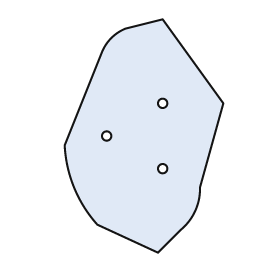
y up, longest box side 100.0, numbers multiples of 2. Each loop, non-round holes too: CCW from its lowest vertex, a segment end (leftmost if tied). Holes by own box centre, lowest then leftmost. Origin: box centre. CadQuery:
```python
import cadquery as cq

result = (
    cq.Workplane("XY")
    .moveTo(6.0, -50.0)
    .lineTo(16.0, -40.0)
    .threePointArc((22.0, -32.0), (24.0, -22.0))
    .lineTo(34.0, 14.0)
    .lineTo(8.0, 50.0)
    .lineTo(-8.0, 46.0)
    .threePointArc((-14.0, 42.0), (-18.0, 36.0))
    .lineTo(-34.0, -4.0)
    .threePointArc((-30.0, -22.0), (-20.0, -38.0))
    .close()
    .moveTo(8.0, -14.0)
    .circle(2.0)
    .moveTo(-16.0, 0.0)
    .circle(2.0)
    .moveTo(8.0, 14.0)
    .circle(2.0)
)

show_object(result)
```